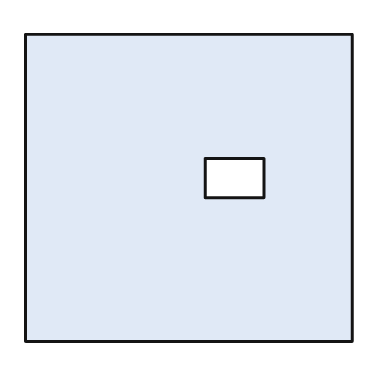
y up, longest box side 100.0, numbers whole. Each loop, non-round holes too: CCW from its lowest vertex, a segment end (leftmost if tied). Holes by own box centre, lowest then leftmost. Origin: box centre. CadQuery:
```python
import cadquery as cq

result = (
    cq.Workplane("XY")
    .moveTo(-50.0, -47.0)
    .lineTo(50.0, -47.0)
    .lineTo(50.0, 47.0)
    .lineTo(-50.0, 47.0)
    .close()
    .moveTo(5.0, -3.0)
    .lineTo(23.0, -3.0)
    .lineTo(23.0, 9.0)
    .lineTo(5.0, 9.0)
    .close()
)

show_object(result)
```